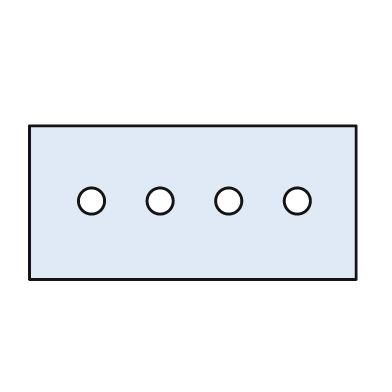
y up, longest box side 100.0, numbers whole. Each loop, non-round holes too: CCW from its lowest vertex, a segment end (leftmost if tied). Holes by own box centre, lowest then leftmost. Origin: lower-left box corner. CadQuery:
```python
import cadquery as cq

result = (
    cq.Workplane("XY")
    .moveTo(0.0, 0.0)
    .lineTo(100.0, 0.0)
    .lineTo(100.0, 47.0)
    .lineTo(0.0, 47.0)
    .close()
    .moveTo(19.0, 24.0)
    .circle(4.0)
    .moveTo(40.0, 24.0)
    .circle(4.0)
    .moveTo(61.0, 24.0)
    .circle(4.0)
    .moveTo(82.0, 24.0)
    .circle(4.0)
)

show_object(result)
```